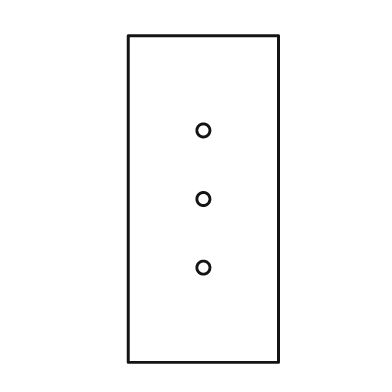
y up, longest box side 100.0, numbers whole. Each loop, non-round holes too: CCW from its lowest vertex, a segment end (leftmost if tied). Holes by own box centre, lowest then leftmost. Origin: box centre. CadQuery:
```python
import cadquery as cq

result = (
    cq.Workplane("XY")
    .moveTo(-23.0, -50.0)
    .lineTo(23.0, -50.0)
    .lineTo(23.0, 50.0)
    .lineTo(-23.0, 50.0)
    .close()
    .moveTo(0.0, -21.0)
    .circle(2.0)
    .moveTo(0.0, 0.0)
    .circle(2.0)
    .moveTo(0.0, 21.0)
    .circle(2.0)
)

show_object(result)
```